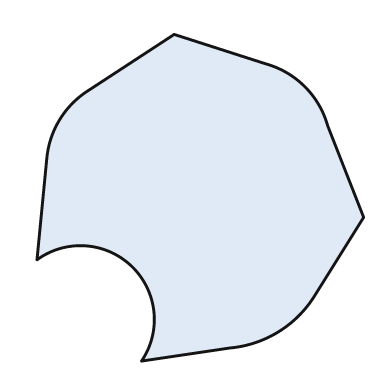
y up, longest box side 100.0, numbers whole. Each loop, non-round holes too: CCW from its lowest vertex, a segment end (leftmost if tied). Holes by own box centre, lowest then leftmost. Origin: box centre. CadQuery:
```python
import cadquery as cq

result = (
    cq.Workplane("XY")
    .moveTo(-18.0, -50.0)
    .lineTo(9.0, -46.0)
    .threePointArc((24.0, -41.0), (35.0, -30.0))
    .lineTo(50.0, -6.0)
    .lineTo(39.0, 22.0)
    .threePointArc((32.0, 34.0), (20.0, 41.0))
    .lineTo(-8.0, 50.0)
    .lineTo(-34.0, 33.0)
    .threePointArc((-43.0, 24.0), (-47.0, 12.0))
    .lineTo(-50.0, -19.0)
    .threePointArc((-21.0, -21.0), (-18.0, -50.0))
    .close()
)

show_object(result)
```